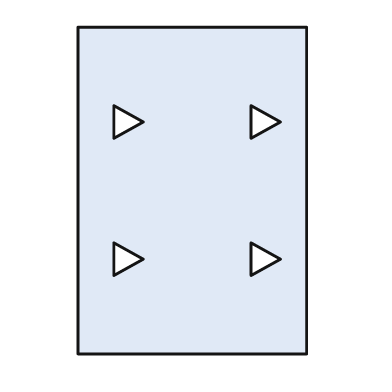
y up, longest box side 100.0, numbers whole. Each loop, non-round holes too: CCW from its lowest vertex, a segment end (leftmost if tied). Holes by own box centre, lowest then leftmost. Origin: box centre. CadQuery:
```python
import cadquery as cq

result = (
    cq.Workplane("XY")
    .moveTo(-35.0, -50.0)
    .lineTo(35.0, -50.0)
    .lineTo(35.0, 50.0)
    .lineTo(-35.0, 50.0)
    .close()
    .moveTo(-24.0, -26.0)
    .lineTo(-15.0, -21.0)
    .lineTo(-24.0, -16.0)
    .close()
    .moveTo(18.0, -26.0)
    .lineTo(27.0, -21.0)
    .lineTo(18.0, -16.0)
    .close()
    .moveTo(-24.0, 16.0)
    .lineTo(-15.0, 21.0)
    .lineTo(-24.0, 26.0)
    .close()
    .moveTo(18.0, 16.0)
    .lineTo(27.0, 21.0)
    .lineTo(18.0, 26.0)
    .close()
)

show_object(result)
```